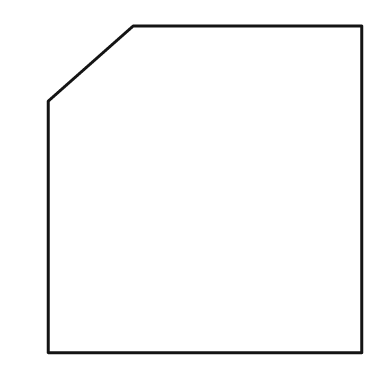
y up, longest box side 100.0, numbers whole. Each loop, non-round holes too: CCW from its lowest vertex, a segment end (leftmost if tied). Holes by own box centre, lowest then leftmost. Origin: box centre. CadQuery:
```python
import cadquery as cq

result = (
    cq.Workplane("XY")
    .moveTo(-48.0, -50.0)
    .lineTo(48.0, -50.0)
    .lineTo(48.0, 50.0)
    .lineTo(-22.0, 50.0)
    .lineTo(-48.0, 27.0)
    .close()
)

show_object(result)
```